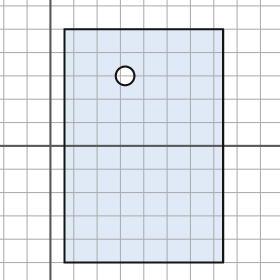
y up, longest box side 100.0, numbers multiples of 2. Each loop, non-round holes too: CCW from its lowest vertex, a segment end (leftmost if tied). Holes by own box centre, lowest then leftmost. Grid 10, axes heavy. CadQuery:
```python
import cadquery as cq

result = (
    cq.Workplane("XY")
    .moveTo(6.0, -50.0)
    .lineTo(74.0, -50.0)
    .lineTo(74.0, 50.0)
    .lineTo(6.0, 50.0)
    .close()
    .moveTo(32.0, 30.0)
    .circle(4.0)
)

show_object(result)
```